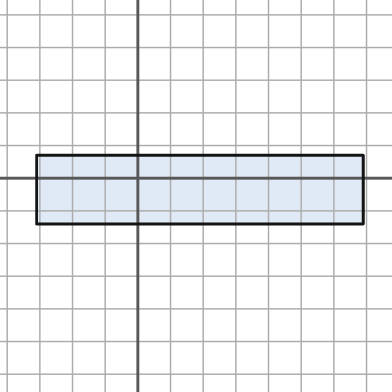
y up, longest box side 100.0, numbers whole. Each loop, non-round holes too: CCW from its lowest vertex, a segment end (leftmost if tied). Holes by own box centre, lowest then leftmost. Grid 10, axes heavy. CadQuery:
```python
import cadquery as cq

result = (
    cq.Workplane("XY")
    .moveTo(-31.0, -14.0)
    .lineTo(69.0, -14.0)
    .lineTo(69.0, 7.0)
    .lineTo(-31.0, 7.0)
    .close()
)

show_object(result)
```